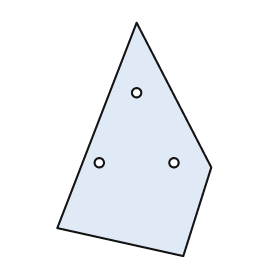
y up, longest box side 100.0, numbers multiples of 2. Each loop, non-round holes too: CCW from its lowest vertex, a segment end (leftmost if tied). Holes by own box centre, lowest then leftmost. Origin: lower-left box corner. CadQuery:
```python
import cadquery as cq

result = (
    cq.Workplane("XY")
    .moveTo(54.0, 0.0)
    .lineTo(66.0, 38.0)
    .lineTo(34.0, 100.0)
    .lineTo(0.0, 12.0)
    .close()
    .moveTo(18.0, 40.0)
    .circle(2.0)
    .moveTo(50.0, 40.0)
    .circle(2.0)
    .moveTo(34.0, 70.0)
    .circle(2.0)
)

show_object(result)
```